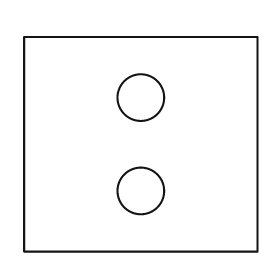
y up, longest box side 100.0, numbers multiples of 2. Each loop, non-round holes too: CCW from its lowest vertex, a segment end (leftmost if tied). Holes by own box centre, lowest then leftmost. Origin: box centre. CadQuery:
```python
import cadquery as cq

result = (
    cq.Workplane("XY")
    .moveTo(-50.0, -46.0)
    .lineTo(50.0, -46.0)
    .lineTo(50.0, 46.0)
    .lineTo(-50.0, 46.0)
    .close()
    .moveTo(0.0, -20.0)
    .circle(10.0)
    .moveTo(0.0, 20.0)
    .circle(10.0)
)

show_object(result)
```